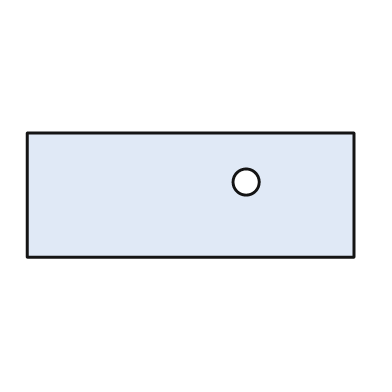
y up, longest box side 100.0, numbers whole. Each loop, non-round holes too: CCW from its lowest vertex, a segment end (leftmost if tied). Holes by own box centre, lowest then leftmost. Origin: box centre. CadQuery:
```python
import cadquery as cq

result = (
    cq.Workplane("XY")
    .moveTo(-50.0, -19.0)
    .lineTo(50.0, -19.0)
    .lineTo(50.0, 19.0)
    .lineTo(-50.0, 19.0)
    .close()
    .moveTo(17.0, 4.0)
    .circle(4.0)
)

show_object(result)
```